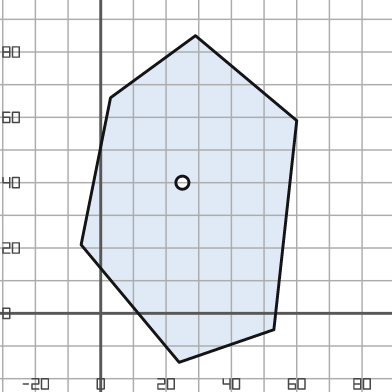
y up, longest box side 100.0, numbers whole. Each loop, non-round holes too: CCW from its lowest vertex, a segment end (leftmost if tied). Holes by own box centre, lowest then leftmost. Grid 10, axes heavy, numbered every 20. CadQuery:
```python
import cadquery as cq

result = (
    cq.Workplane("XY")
    .moveTo(24.0, -15.0)
    .lineTo(53.0, -5.0)
    .lineTo(60.0, 59.0)
    .lineTo(29.0, 85.0)
    .lineTo(3.0, 66.0)
    .lineTo(-6.0, 21.0)
    .close()
    .moveTo(25.0, 40.0)
    .circle(2.0)
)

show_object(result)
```